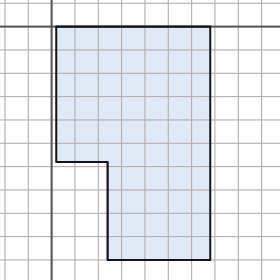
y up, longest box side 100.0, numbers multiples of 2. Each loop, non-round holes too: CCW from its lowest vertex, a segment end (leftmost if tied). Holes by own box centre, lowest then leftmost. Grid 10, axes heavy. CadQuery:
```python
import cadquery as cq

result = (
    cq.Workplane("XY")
    .moveTo(24.0, -100.0)
    .lineTo(68.0, -100.0)
    .lineTo(68.0, 0.0)
    .lineTo(2.0, 0.0)
    .lineTo(2.0, -58.0)
    .lineTo(24.0, -58.0)
    .close()
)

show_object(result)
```